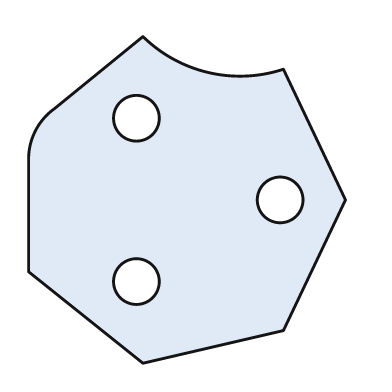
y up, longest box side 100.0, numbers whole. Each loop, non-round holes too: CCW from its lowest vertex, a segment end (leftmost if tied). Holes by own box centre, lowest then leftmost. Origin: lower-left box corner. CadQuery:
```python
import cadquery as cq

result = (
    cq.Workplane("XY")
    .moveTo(35.0, 0.0)
    .lineTo(78.0, 10.0)
    .lineTo(97.0, 50.0)
    .lineTo(78.0, 90.0)
    .threePointArc((55.0, 89.0), (35.0, 100.0))
    .lineTo(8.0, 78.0)
    .threePointArc((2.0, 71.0), (0.0, 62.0))
    .lineTo(0.0, 28.0)
    .close()
    .moveTo(33.0, 25.0)
    .circle(7.0)
    .moveTo(77.0, 50.0)
    .circle(7.0)
    .moveTo(33.0, 75.0)
    .circle(7.0)
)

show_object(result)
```